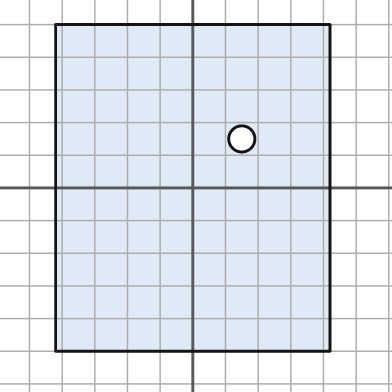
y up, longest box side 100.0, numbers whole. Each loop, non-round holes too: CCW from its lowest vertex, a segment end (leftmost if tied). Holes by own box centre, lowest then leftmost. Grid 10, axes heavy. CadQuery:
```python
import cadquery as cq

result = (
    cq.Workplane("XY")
    .moveTo(-42.0, -50.0)
    .lineTo(42.0, -50.0)
    .lineTo(42.0, 50.0)
    .lineTo(-42.0, 50.0)
    .close()
    .moveTo(15.0, 15.0)
    .circle(4.0)
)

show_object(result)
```